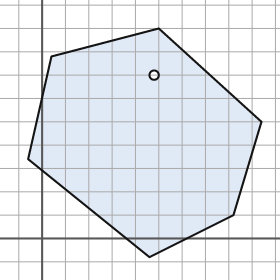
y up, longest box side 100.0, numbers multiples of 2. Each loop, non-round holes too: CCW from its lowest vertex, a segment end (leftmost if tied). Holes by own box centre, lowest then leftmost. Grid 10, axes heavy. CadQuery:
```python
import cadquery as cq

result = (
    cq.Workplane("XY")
    .moveTo(46.0, -8.0)
    .lineTo(82.0, 10.0)
    .lineTo(94.0, 50.0)
    .lineTo(50.0, 90.0)
    .lineTo(4.0, 78.0)
    .lineTo(-6.0, 34.0)
    .close()
    .moveTo(48.0, 70.0)
    .circle(2.0)
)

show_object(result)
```